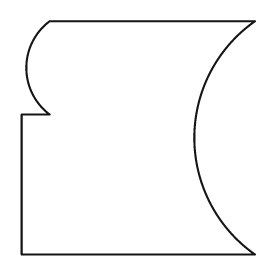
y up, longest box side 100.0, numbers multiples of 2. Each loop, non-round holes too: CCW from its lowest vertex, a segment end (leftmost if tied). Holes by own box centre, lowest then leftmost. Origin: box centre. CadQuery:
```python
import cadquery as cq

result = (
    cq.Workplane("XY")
    .moveTo(-50.0, -50.0)
    .lineTo(50.0, -50.0)
    .threePointArc((24.0, 0.0), (50.0, 50.0))
    .lineTo(-38.0, 50.0)
    .threePointArc((-48.0, 30.0), (-38.0, 10.0))
    .lineTo(-50.0, 10.0)
    .close()
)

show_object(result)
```